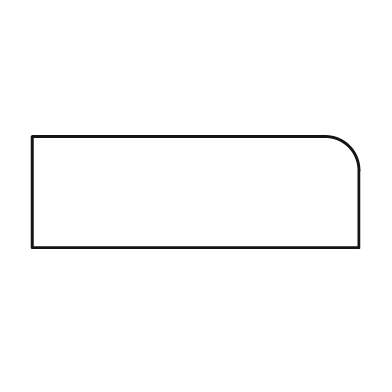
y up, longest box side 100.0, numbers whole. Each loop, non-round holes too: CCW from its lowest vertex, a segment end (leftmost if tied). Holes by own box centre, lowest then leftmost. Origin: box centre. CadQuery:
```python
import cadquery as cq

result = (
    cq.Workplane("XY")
    .moveTo(-50.0, -17.0)
    .lineTo(50.0, -17.0)
    .lineTo(50.0, 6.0)
    .threePointArc((47.0, 14.0), (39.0, 17.0))
    .lineTo(-50.0, 17.0)
    .close()
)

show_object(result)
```